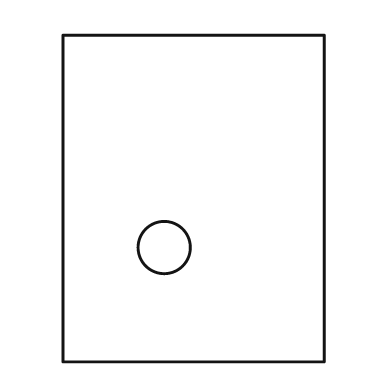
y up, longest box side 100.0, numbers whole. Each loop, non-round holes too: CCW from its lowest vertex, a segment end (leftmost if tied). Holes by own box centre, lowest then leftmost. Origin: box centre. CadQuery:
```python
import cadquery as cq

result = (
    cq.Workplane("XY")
    .moveTo(-40.0, -50.0)
    .lineTo(40.0, -50.0)
    .lineTo(40.0, 50.0)
    .lineTo(-40.0, 50.0)
    .close()
    .moveTo(-9.0, -15.0)
    .circle(8.0)
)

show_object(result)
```